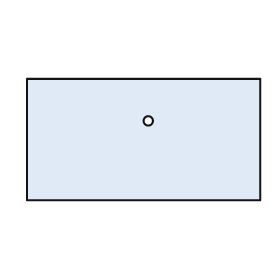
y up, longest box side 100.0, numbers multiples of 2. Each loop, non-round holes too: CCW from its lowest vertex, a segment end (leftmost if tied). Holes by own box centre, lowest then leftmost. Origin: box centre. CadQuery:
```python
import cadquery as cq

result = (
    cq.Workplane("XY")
    .moveTo(-50.0, -26.0)
    .lineTo(50.0, -26.0)
    .lineTo(50.0, 26.0)
    .lineTo(-50.0, 26.0)
    .close()
    .moveTo(2.0, 8.0)
    .circle(2.0)
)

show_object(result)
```